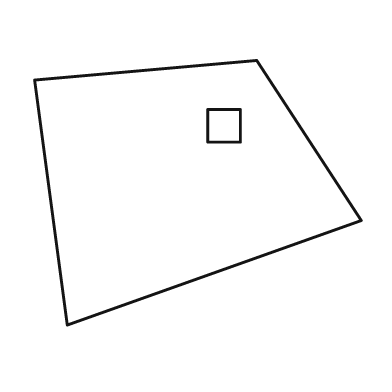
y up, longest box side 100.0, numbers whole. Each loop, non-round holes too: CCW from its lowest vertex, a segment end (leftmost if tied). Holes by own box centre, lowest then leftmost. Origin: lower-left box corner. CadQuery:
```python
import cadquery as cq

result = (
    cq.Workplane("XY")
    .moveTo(10.0, 0.0)
    .lineTo(100.0, 32.0)
    .lineTo(68.0, 81.0)
    .lineTo(0.0, 75.0)
    .close()
    .moveTo(53.0, 56.0)
    .lineTo(63.0, 56.0)
    .lineTo(63.0, 66.0)
    .lineTo(53.0, 66.0)
    .close()
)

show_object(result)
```